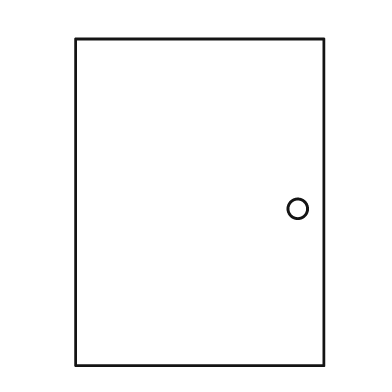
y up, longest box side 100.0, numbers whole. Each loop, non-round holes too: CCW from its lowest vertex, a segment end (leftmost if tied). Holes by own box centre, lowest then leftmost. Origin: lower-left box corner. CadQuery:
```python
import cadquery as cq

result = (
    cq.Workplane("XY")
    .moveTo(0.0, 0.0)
    .lineTo(76.0, 0.0)
    .lineTo(76.0, 100.0)
    .lineTo(0.0, 100.0)
    .close()
    .moveTo(68.0, 48.0)
    .circle(3.0)
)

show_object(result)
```